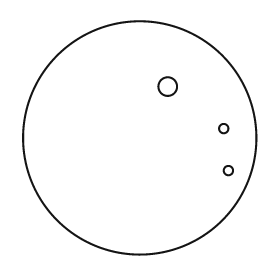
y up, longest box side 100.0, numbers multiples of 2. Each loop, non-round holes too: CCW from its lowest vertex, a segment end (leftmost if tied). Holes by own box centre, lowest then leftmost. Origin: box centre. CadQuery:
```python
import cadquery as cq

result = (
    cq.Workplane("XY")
    .moveTo(0.0, 0.0)
    .circle(50.0)
    .moveTo(38.0, -14.0)
    .circle(2.0)
    .moveTo(36.0, 4.0)
    .circle(2.0)
    .moveTo(12.0, 22.0)
    .circle(4.0)
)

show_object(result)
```